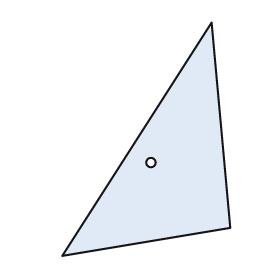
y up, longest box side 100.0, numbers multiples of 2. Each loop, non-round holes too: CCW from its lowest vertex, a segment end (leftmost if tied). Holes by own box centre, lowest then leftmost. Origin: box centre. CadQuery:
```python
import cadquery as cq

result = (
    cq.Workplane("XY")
    .moveTo(-36.0, -50.0)
    .lineTo(36.0, -38.0)
    .lineTo(28.0, 50.0)
    .close()
    .moveTo(2.0, -10.0)
    .circle(2.0)
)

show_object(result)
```